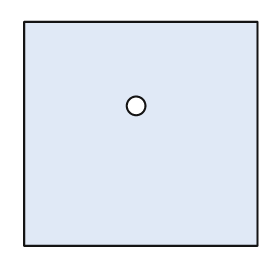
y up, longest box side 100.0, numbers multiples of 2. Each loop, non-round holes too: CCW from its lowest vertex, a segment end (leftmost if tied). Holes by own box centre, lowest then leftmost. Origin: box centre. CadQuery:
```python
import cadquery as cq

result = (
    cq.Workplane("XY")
    .moveTo(-50.0, -48.0)
    .lineTo(50.0, -48.0)
    .lineTo(50.0, 48.0)
    .lineTo(-50.0, 48.0)
    .close()
    .moveTo(-2.0, 12.0)
    .circle(4.0)
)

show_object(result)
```